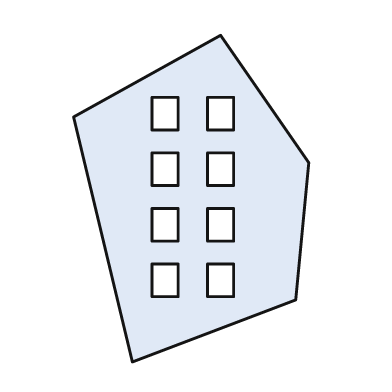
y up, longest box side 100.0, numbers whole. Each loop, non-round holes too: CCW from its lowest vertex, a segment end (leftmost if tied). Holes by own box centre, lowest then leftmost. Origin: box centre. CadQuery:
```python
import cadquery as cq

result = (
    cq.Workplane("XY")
    .moveTo(-18.0, -50.0)
    .lineTo(32.0, -31.0)
    .lineTo(36.0, 11.0)
    .lineTo(9.0, 50.0)
    .lineTo(-36.0, 25.0)
    .close()
    .moveTo(-12.0, -30.0)
    .lineTo(-4.0, -30.0)
    .lineTo(-4.0, -20.0)
    .lineTo(-12.0, -20.0)
    .close()
    .moveTo(5.0, -30.0)
    .lineTo(13.0, -30.0)
    .lineTo(13.0, -20.0)
    .lineTo(5.0, -20.0)
    .close()
    .moveTo(-12.0, -13.0)
    .lineTo(-4.0, -13.0)
    .lineTo(-4.0, -3.0)
    .lineTo(-12.0, -3.0)
    .close()
    .moveTo(5.0, -13.0)
    .lineTo(13.0, -13.0)
    .lineTo(13.0, -3.0)
    .lineTo(5.0, -3.0)
    .close()
    .moveTo(-12.0, 4.0)
    .lineTo(-4.0, 4.0)
    .lineTo(-4.0, 14.0)
    .lineTo(-12.0, 14.0)
    .close()
    .moveTo(5.0, 4.0)
    .lineTo(13.0, 4.0)
    .lineTo(13.0, 14.0)
    .lineTo(5.0, 14.0)
    .close()
    .moveTo(-12.0, 21.0)
    .lineTo(-4.0, 21.0)
    .lineTo(-4.0, 31.0)
    .lineTo(-12.0, 31.0)
    .close()
    .moveTo(5.0, 21.0)
    .lineTo(13.0, 21.0)
    .lineTo(13.0, 31.0)
    .lineTo(5.0, 31.0)
    .close()
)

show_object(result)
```